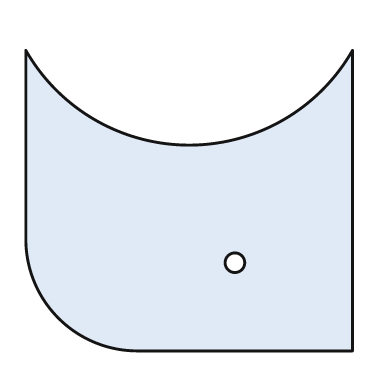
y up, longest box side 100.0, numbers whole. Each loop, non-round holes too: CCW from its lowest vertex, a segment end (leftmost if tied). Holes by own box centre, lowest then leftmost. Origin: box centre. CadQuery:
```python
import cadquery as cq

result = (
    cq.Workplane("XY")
    .moveTo(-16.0, -46.0)
    .lineTo(50.0, -46.0)
    .lineTo(50.0, 46.0)
    .threePointArc((0.0, 17.0), (-50.0, 46.0))
    .lineTo(-50.0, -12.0)
    .threePointArc((-40.0, -36.0), (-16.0, -46.0))
    .close()
    .moveTo(14.0, -19.0)
    .circle(3.0)
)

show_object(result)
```